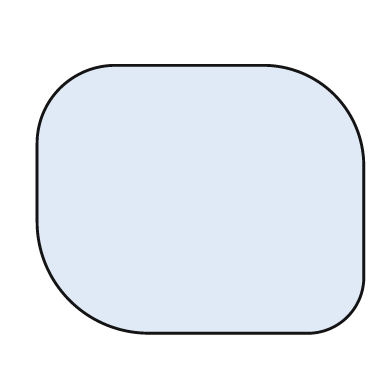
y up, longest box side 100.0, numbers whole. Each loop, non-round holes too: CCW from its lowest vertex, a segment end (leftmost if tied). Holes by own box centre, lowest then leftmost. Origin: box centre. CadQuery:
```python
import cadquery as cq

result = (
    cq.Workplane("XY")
    .moveTo(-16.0, -41.0)
    .lineTo(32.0, -41.0)
    .threePointArc((45.0, -36.0), (50.0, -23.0))
    .lineTo(50.0, 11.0)
    .threePointArc((41.0, 32.0), (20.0, 41.0))
    .lineTo(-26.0, 41.0)
    .threePointArc((-43.0, 34.0), (-50.0, 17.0))
    .lineTo(-50.0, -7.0)
    .threePointArc((-40.0, -31.0), (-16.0, -41.0))
    .close()
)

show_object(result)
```